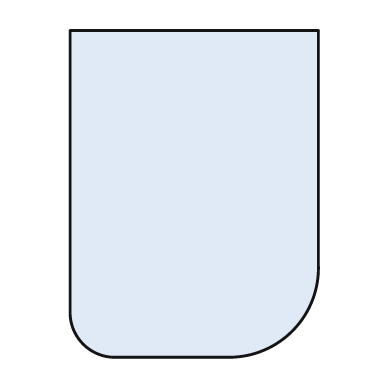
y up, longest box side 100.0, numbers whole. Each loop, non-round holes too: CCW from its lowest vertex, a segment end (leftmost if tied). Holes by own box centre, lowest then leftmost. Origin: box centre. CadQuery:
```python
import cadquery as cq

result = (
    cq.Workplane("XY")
    .moveTo(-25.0, -50.0)
    .lineTo(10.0, -50.0)
    .threePointArc((30.0, -42.0), (38.0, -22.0))
    .lineTo(38.0, 50.0)
    .lineTo(-38.0, 50.0)
    .lineTo(-38.0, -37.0)
    .threePointArc((-34.0, -46.0), (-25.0, -50.0))
    .close()
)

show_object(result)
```